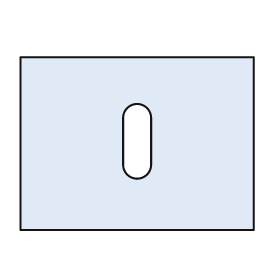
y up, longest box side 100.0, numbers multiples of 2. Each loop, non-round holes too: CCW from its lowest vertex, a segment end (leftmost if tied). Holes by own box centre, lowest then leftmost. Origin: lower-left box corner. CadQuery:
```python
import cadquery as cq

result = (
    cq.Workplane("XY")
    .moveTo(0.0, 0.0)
    .lineTo(100.0, 0.0)
    .lineTo(100.0, 74.0)
    .lineTo(0.0, 74.0)
    .close()
    .moveTo(44.0, 28.0)
    .threePointArc((50.0, 22.0), (56.0, 28.0))
    .lineTo(56.0, 48.0)
    .threePointArc((50.0, 54.0), (44.0, 48.0))
    .close()
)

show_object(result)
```